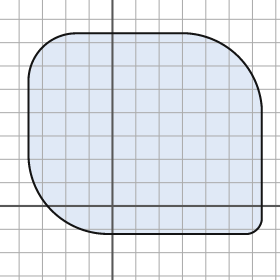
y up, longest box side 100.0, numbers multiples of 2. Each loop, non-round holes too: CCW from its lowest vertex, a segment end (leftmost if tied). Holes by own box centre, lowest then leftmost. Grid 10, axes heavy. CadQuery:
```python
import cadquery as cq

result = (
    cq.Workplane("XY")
    .moveTo(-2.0, -12.0)
    .lineTo(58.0, -12.0)
    .threePointArc((62.0, -10.0), (64.0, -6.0))
    .lineTo(64.0, 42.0)
    .threePointArc((54.0, 64.0), (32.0, 74.0))
    .lineTo(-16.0, 74.0)
    .threePointArc((-30.0, 68.0), (-36.0, 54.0))
    .lineTo(-36.0, 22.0)
    .threePointArc((-26.0, -2.0), (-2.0, -12.0))
    .close()
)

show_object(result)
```